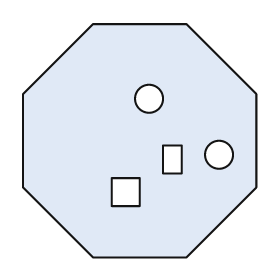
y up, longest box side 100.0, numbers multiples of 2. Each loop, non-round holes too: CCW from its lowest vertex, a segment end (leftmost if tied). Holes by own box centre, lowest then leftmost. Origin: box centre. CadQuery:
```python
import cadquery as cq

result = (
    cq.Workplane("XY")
    .moveTo(-20.0, -50.0)
    .lineTo(20.0, -50.0)
    .lineTo(50.0, -20.0)
    .lineTo(50.0, 20.0)
    .lineTo(20.0, 50.0)
    .lineTo(-20.0, 50.0)
    .lineTo(-50.0, 20.0)
    .lineTo(-50.0, -20.0)
    .close()
    .moveTo(-12.0, -28.0)
    .lineTo(0.0, -28.0)
    .lineTo(0.0, -16.0)
    .lineTo(-12.0, -16.0)
    .close()
    .moveTo(10.0, -14.0)
    .lineTo(18.0, -14.0)
    .lineTo(18.0, -2.0)
    .lineTo(10.0, -2.0)
    .close()
    .moveTo(34.0, -6.0)
    .circle(6.0)
    .moveTo(4.0, 18.0)
    .circle(6.0)
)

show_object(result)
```